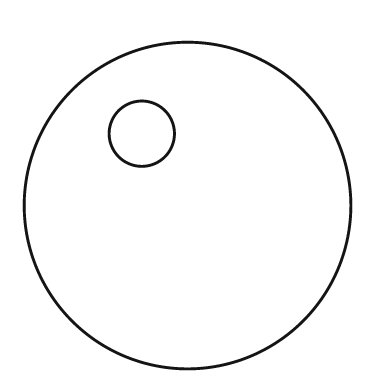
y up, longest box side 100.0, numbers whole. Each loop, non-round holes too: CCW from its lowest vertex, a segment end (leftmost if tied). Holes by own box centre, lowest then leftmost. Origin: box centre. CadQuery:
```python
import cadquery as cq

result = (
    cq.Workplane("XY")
    .moveTo(0.0, 0.0)
    .circle(50.0)
    .moveTo(-14.0, 22.0)
    .circle(10.0)
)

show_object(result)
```